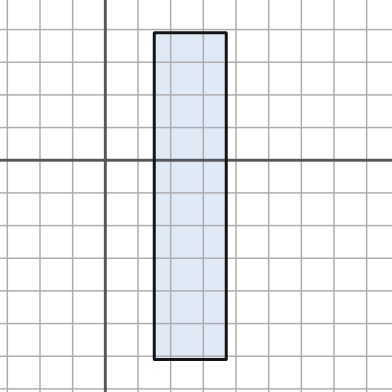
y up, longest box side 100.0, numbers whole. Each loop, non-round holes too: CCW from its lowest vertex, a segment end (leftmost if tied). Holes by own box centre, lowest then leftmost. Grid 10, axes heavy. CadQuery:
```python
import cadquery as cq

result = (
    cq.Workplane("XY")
    .moveTo(15.0, -61.0)
    .lineTo(37.0, -61.0)
    .lineTo(37.0, 39.0)
    .lineTo(15.0, 39.0)
    .close()
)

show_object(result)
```